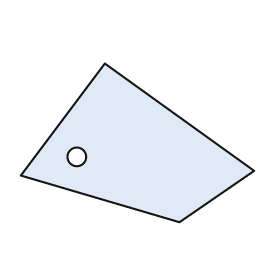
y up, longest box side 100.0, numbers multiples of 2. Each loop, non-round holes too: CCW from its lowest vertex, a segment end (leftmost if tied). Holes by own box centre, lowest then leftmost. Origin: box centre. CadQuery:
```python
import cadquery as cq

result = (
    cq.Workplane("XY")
    .moveTo(18.0, -34.0)
    .lineTo(50.0, -12.0)
    .lineTo(-14.0, 34.0)
    .lineTo(-50.0, -14.0)
    .close()
    .moveTo(-26.0, -6.0)
    .circle(4.0)
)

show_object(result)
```